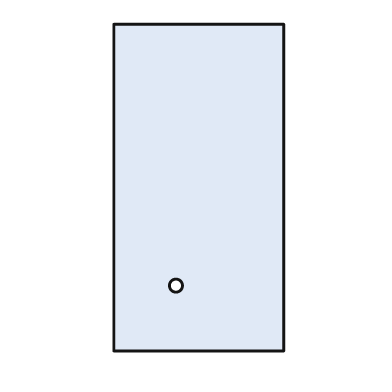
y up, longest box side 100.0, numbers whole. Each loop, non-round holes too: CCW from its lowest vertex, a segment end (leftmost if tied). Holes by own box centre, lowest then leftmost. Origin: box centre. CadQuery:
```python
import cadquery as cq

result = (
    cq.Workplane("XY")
    .moveTo(-26.0, -50.0)
    .lineTo(26.0, -50.0)
    .lineTo(26.0, 50.0)
    .lineTo(-26.0, 50.0)
    .close()
    .moveTo(-7.0, -30.0)
    .circle(2.0)
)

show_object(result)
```